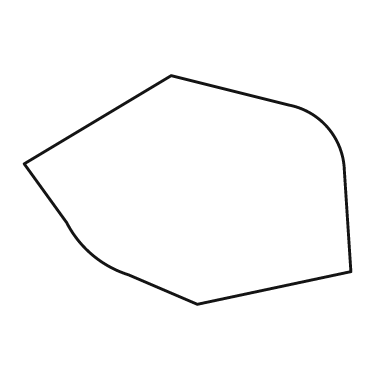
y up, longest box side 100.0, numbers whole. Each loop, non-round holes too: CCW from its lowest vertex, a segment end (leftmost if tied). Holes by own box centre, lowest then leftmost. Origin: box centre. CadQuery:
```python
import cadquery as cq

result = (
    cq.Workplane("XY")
    .moveTo(3.0, -35.0)
    .lineTo(50.0, -25.0)
    .lineTo(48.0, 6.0)
    .threePointArc((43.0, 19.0), (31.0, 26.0))
    .lineTo(-5.0, 35.0)
    .lineTo(-50.0, 8.0)
    .lineTo(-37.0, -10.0)
    .threePointArc((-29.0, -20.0), (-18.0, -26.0))
    .close()
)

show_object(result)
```